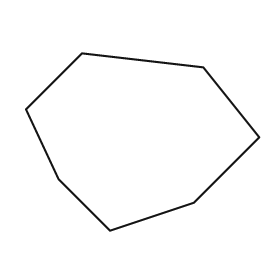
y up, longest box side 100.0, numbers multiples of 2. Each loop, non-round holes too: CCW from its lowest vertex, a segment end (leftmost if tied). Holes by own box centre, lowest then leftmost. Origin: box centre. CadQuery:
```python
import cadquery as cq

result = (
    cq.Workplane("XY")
    .moveTo(-14.0, -38.0)
    .lineTo(22.0, -26.0)
    .lineTo(50.0, 2.0)
    .lineTo(26.0, 32.0)
    .lineTo(-26.0, 38.0)
    .lineTo(-50.0, 14.0)
    .lineTo(-36.0, -16.0)
    .close()
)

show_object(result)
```